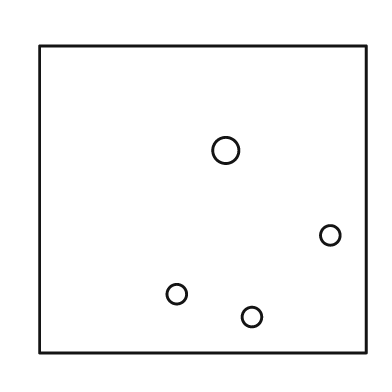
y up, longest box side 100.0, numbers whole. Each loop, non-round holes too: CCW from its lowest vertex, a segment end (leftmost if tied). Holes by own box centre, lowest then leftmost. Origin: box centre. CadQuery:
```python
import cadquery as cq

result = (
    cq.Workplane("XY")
    .moveTo(-50.0, -47.0)
    .lineTo(50.0, -47.0)
    .lineTo(50.0, 47.0)
    .lineTo(-50.0, 47.0)
    .close()
    .moveTo(15.0, -36.0)
    .circle(3.0)
    .moveTo(-8.0, -29.0)
    .circle(3.0)
    .moveTo(39.0, -11.0)
    .circle(3.0)
    .moveTo(7.0, 15.0)
    .circle(4.0)
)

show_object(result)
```